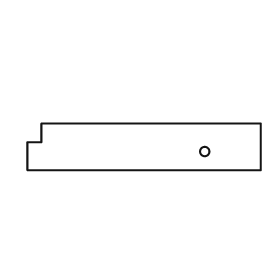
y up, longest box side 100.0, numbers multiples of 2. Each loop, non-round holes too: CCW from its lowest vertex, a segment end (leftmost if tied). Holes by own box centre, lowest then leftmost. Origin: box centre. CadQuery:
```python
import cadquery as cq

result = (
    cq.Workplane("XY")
    .moveTo(-50.0, -10.0)
    .lineTo(50.0, -10.0)
    .lineTo(50.0, 10.0)
    .lineTo(-44.0, 10.0)
    .lineTo(-44.0, 2.0)
    .lineTo(-50.0, 2.0)
    .close()
    .moveTo(26.0, -2.0)
    .circle(2.0)
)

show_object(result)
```